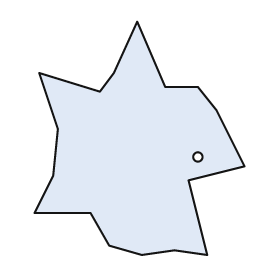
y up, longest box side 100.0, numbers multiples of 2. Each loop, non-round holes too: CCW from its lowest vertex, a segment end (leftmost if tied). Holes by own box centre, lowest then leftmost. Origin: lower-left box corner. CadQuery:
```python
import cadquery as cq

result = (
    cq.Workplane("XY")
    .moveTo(46.0, 0.0)
    .lineTo(60.0, 2.0)
    .lineTo(74.0, 0.0)
    .lineTo(66.0, 32.0)
    .lineTo(90.0, 38.0)
    .lineTo(78.0, 62.0)
    .lineTo(70.0, 72.0)
    .lineTo(56.0, 72.0)
    .lineTo(44.0, 100.0)
    .lineTo(34.0, 78.0)
    .lineTo(28.0, 70.0)
    .lineTo(2.0, 78.0)
    .lineTo(10.0, 54.0)
    .lineTo(8.0, 34.0)
    .lineTo(0.0, 18.0)
    .lineTo(24.0, 18.0)
    .lineTo(32.0, 4.0)
    .close()
    .moveTo(70.0, 42.0)
    .circle(2.0)
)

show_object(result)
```